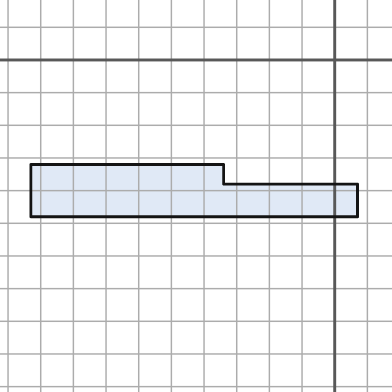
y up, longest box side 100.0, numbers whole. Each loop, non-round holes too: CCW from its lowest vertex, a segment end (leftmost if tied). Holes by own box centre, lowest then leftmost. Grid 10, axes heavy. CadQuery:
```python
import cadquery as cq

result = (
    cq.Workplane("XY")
    .moveTo(-93.0, -48.0)
    .lineTo(7.0, -48.0)
    .lineTo(7.0, -38.0)
    .lineTo(-34.0, -38.0)
    .lineTo(-34.0, -32.0)
    .lineTo(-93.0, -32.0)
    .close()
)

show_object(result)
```